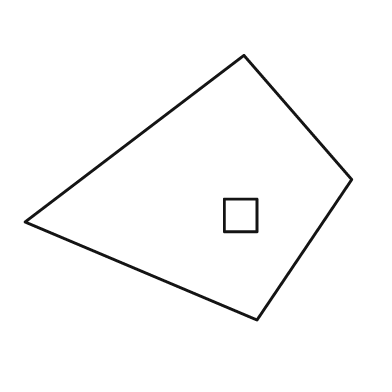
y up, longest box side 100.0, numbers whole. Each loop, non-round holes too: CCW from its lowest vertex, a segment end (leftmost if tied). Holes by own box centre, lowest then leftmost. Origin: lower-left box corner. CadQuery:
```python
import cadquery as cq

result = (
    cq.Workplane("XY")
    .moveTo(71.0, 0.0)
    .lineTo(100.0, 43.0)
    .lineTo(67.0, 81.0)
    .lineTo(0.0, 30.0)
    .close()
    .moveTo(61.0, 27.0)
    .lineTo(71.0, 27.0)
    .lineTo(71.0, 37.0)
    .lineTo(61.0, 37.0)
    .close()
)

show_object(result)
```